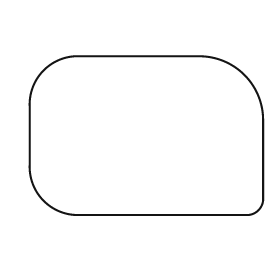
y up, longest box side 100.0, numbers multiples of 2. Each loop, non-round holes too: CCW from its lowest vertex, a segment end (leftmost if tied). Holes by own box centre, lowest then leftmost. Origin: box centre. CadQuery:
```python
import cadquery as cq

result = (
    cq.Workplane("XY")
    .moveTo(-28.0, -34.0)
    .lineTo(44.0, -34.0)
    .threePointArc((48.0, -32.0), (50.0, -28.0))
    .lineTo(50.0, 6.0)
    .threePointArc((42.0, 26.0), (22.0, 34.0))
    .lineTo(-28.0, 34.0)
    .threePointArc((-44.0, 28.0), (-50.0, 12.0))
    .lineTo(-50.0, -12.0)
    .threePointArc((-44.0, -28.0), (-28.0, -34.0))
    .close()
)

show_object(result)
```